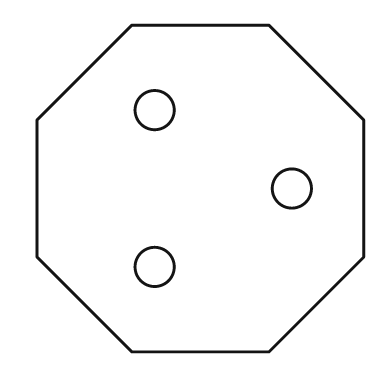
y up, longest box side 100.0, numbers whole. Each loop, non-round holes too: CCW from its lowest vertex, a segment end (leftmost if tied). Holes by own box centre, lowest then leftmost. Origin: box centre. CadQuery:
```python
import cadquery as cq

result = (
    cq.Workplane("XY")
    .moveTo(-21.0, -50.0)
    .lineTo(21.0, -50.0)
    .lineTo(50.0, -21.0)
    .lineTo(50.0, 21.0)
    .lineTo(21.0, 50.0)
    .lineTo(-21.0, 50.0)
    .lineTo(-50.0, 21.0)
    .lineTo(-50.0, -21.0)
    .close()
    .moveTo(-14.0, -24.0)
    .circle(6.0)
    .moveTo(28.0, 0.0)
    .circle(6.0)
    .moveTo(-14.0, 24.0)
    .circle(6.0)
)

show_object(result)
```